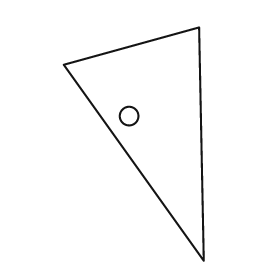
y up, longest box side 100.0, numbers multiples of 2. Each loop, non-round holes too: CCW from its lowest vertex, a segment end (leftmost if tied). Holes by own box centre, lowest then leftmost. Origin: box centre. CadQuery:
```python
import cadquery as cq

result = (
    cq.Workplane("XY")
    .moveTo(30.0, -50.0)
    .lineTo(28.0, 50.0)
    .lineTo(-30.0, 34.0)
    .close()
    .moveTo(-2.0, 12.0)
    .circle(4.0)
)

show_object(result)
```